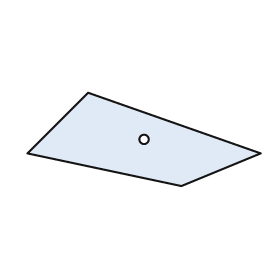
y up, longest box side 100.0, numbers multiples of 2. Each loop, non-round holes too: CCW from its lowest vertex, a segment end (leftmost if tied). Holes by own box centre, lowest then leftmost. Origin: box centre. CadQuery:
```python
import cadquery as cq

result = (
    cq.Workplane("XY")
    .moveTo(16.0, -20.0)
    .lineTo(50.0, -6.0)
    .lineTo(-24.0, 20.0)
    .lineTo(-50.0, -6.0)
    .close()
    .moveTo(0.0, 0.0)
    .circle(2.0)
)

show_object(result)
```